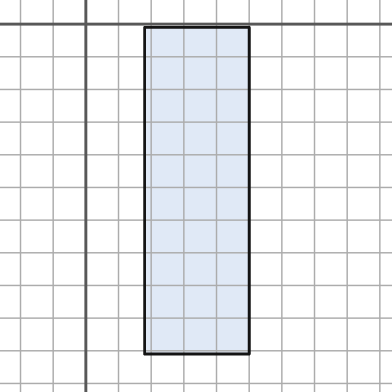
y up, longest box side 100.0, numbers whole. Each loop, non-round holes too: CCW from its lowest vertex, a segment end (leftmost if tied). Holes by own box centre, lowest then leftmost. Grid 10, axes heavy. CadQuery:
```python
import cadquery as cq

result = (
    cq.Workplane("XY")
    .moveTo(18.0, -101.0)
    .lineTo(50.0, -101.0)
    .lineTo(50.0, -1.0)
    .lineTo(18.0, -1.0)
    .close()
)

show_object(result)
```